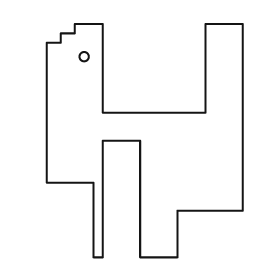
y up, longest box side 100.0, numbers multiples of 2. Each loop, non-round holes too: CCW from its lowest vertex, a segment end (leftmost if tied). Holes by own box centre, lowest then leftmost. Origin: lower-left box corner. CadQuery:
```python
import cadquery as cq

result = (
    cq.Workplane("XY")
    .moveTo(20.0, 0.0)
    .lineTo(24.0, 0.0)
    .lineTo(24.0, 50.0)
    .lineTo(40.0, 50.0)
    .lineTo(40.0, 0.0)
    .lineTo(56.0, 0.0)
    .lineTo(56.0, 20.0)
    .lineTo(84.0, 20.0)
    .lineTo(84.0, 100.0)
    .lineTo(68.0, 100.0)
    .lineTo(68.0, 62.0)
    .lineTo(24.0, 62.0)
    .lineTo(24.0, 100.0)
    .lineTo(12.0, 100.0)
    .lineTo(12.0, 96.0)
    .lineTo(6.0, 96.0)
    .lineTo(6.0, 92.0)
    .lineTo(0.0, 92.0)
    .lineTo(0.0, 32.0)
    .lineTo(20.0, 32.0)
    .close()
    .moveTo(16.0, 86.0)
    .circle(2.0)
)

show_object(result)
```